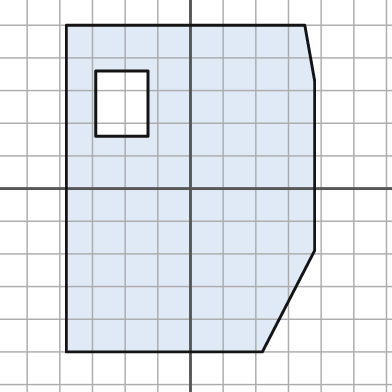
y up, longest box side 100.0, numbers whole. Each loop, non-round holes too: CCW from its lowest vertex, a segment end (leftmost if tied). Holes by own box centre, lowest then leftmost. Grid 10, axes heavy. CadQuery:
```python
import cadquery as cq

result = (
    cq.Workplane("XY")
    .moveTo(-38.0, -50.0)
    .lineTo(22.0, -50.0)
    .lineTo(38.0, -19.0)
    .lineTo(38.0, 33.0)
    .lineTo(35.0, 50.0)
    .lineTo(-38.0, 50.0)
    .close()
    .moveTo(-29.0, 16.0)
    .lineTo(-13.0, 16.0)
    .lineTo(-13.0, 36.0)
    .lineTo(-29.0, 36.0)
    .close()
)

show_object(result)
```